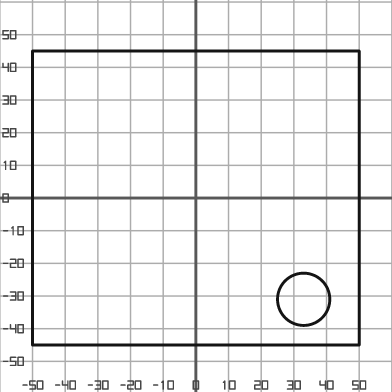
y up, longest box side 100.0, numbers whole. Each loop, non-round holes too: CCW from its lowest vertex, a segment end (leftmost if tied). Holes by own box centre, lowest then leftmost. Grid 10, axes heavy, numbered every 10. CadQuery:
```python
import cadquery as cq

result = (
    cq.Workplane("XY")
    .moveTo(-50.0, -45.0)
    .lineTo(50.0, -45.0)
    .lineTo(50.0, 45.0)
    .lineTo(-50.0, 45.0)
    .close()
    .moveTo(33.0, -31.0)
    .circle(8.0)
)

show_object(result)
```